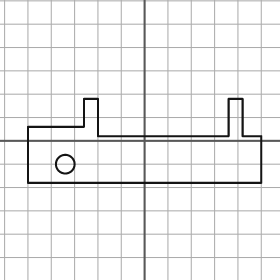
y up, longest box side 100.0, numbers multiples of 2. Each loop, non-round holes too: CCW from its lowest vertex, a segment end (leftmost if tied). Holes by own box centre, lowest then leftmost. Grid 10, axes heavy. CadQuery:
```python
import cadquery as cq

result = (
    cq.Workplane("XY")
    .moveTo(-50.0, -18.0)
    .lineTo(50.0, -18.0)
    .lineTo(50.0, 2.0)
    .lineTo(42.0, 2.0)
    .lineTo(42.0, 18.0)
    .lineTo(36.0, 18.0)
    .lineTo(36.0, 2.0)
    .lineTo(-20.0, 2.0)
    .lineTo(-20.0, 18.0)
    .lineTo(-26.0, 18.0)
    .lineTo(-26.0, 6.0)
    .lineTo(-50.0, 6.0)
    .close()
    .moveTo(-34.0, -10.0)
    .circle(4.0)
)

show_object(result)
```